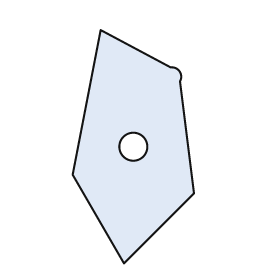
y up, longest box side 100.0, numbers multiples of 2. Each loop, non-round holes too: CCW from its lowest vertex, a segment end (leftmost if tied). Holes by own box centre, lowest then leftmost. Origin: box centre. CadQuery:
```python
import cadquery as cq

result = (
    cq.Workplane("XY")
    .moveTo(-4.0, -50.0)
    .lineTo(26.0, -20.0)
    .lineTo(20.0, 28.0)
    .threePointArc((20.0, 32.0), (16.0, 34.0))
    .lineTo(-14.0, 50.0)
    .lineTo(-26.0, -12.0)
    .close()
    .moveTo(0.0, 0.0)
    .circle(6.0)
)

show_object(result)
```